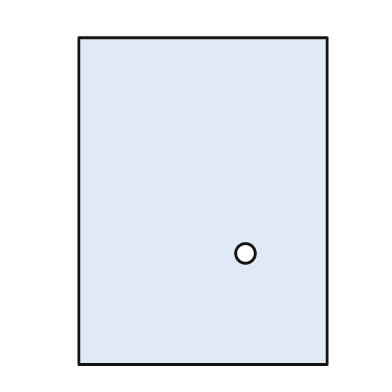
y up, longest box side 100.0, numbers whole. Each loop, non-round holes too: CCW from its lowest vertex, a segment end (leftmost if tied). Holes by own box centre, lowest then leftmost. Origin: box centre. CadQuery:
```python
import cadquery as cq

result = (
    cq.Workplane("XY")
    .moveTo(-38.0, -50.0)
    .lineTo(38.0, -50.0)
    .lineTo(38.0, 50.0)
    .lineTo(-38.0, 50.0)
    .close()
    .moveTo(13.0, -16.0)
    .circle(3.0)
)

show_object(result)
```